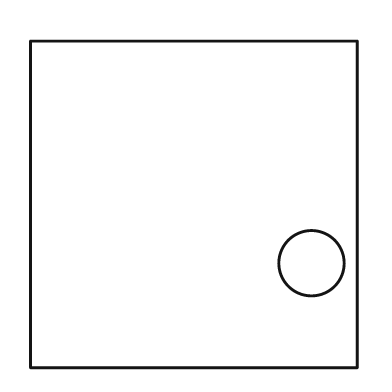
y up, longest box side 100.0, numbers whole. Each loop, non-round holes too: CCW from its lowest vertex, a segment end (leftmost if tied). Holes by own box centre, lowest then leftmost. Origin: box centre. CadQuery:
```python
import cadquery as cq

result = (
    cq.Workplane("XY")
    .moveTo(-50.0, -50.0)
    .lineTo(50.0, -50.0)
    .lineTo(50.0, 50.0)
    .lineTo(-50.0, 50.0)
    .close()
    .moveTo(36.0, -18.0)
    .circle(10.0)
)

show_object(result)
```